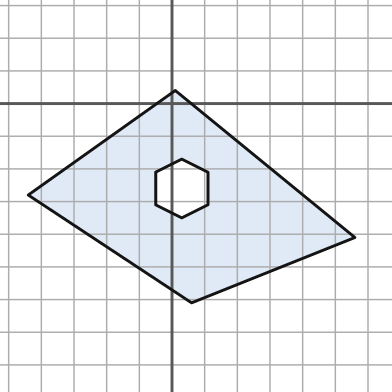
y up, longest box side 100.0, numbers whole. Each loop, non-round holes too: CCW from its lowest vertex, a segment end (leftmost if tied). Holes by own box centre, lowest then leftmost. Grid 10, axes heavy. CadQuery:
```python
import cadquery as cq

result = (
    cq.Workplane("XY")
    .moveTo(6.0, -61.0)
    .lineTo(56.0, -41.0)
    .lineTo(1.0, 4.0)
    .lineTo(-44.0, -28.0)
    .close()
    .moveTo(3.0, -35.0)
    .lineTo(11.0, -31.0)
    .lineTo(11.0, -21.0)
    .lineTo(3.0, -17.0)
    .lineTo(-5.0, -21.0)
    .lineTo(-5.0, -31.0)
    .close()
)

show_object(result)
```